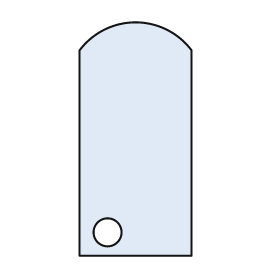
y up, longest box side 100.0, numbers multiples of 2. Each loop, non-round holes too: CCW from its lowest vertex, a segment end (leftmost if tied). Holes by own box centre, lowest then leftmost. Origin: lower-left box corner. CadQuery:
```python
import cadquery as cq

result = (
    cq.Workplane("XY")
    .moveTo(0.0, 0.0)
    .lineTo(48.0, 0.0)
    .lineTo(48.0, 88.0)
    .threePointArc((24.0, 100.0), (0.0, 88.0))
    .close()
    .moveTo(12.0, 10.0)
    .circle(6.0)
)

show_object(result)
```